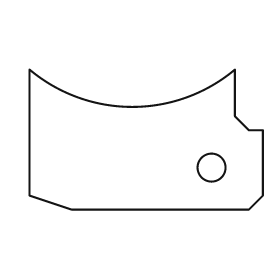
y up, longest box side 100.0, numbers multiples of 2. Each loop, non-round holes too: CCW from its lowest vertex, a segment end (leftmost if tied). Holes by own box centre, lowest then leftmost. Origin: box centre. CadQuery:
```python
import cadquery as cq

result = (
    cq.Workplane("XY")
    .moveTo(-32.0, -30.0)
    .lineTo(44.0, -30.0)
    .lineTo(50.0, -24.0)
    .lineTo(50.0, 4.0)
    .lineTo(44.0, 4.0)
    .lineTo(38.0, 10.0)
    .lineTo(38.0, 30.0)
    .threePointArc((-6.0, 14.0), (-50.0, 30.0))
    .lineTo(-50.0, -24.0)
    .close()
    .moveTo(28.0, -12.0)
    .circle(6.0)
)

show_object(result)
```